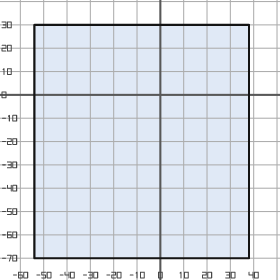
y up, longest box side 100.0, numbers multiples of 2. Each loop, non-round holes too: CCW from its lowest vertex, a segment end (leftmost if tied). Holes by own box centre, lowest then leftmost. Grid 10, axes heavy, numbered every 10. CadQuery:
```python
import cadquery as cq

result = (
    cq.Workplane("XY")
    .moveTo(-54.0, -70.0)
    .lineTo(38.0, -70.0)
    .lineTo(38.0, 30.0)
    .lineTo(-54.0, 30.0)
    .close()
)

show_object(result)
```